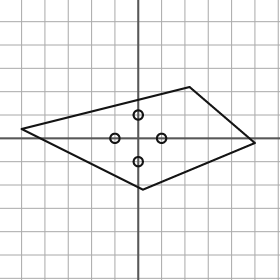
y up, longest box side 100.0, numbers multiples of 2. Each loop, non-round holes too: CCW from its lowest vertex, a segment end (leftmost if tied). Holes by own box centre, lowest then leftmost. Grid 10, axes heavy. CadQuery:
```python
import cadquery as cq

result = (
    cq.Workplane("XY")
    .moveTo(2.0, -22.0)
    .lineTo(50.0, -2.0)
    .lineTo(22.0, 22.0)
    .lineTo(-50.0, 4.0)
    .close()
    .moveTo(0.0, -10.0)
    .circle(2.0)
    .moveTo(-10.0, 0.0)
    .circle(2.0)
    .moveTo(10.0, 0.0)
    .circle(2.0)
    .moveTo(0.0, 10.0)
    .circle(2.0)
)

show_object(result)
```